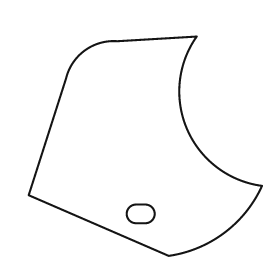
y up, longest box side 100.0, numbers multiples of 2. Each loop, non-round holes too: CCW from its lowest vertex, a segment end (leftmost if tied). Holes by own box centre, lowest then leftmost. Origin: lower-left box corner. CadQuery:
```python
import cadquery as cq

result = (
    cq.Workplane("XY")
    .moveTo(60.0, 0.0)
    .threePointArc((84.0, 10.0), (100.0, 30.0))
    .threePointArc((68.0, 54.0), (72.0, 94.0))
    .lineTo(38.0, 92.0)
    .threePointArc((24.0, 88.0), (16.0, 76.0))
    .lineTo(0.0, 26.0)
    .close()
    .moveTo(46.0, 14.0)
    .lineTo(50.0, 14.0)
    .threePointArc((54.0, 18.0), (50.0, 22.0))
    .lineTo(46.0, 22.0)
    .threePointArc((42.0, 18.0), (46.0, 14.0))
    .close()
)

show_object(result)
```